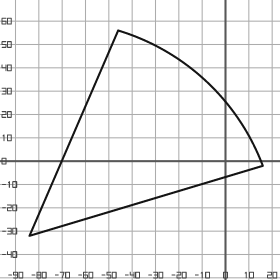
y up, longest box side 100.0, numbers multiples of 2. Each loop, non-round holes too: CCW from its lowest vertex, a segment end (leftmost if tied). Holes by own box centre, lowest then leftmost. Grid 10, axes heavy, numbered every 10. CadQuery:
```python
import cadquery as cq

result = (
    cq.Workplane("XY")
    .moveTo(-84.0, -32.0)
    .lineTo(16.0, -2.0)
    .threePointArc((-8.0, 34.0), (-46.0, 56.0))
    .close()
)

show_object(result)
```